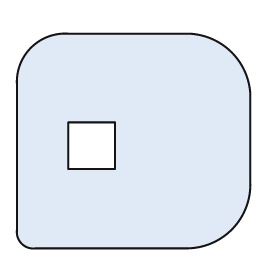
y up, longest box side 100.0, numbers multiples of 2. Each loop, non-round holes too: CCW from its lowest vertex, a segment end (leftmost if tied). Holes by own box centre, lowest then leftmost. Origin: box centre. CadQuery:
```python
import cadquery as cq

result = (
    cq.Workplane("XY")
    .moveTo(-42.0, -46.0)
    .lineTo(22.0, -46.0)
    .threePointArc((42.0, -38.0), (50.0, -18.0))
    .lineTo(50.0, 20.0)
    .threePointArc((42.0, 38.0), (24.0, 46.0))
    .lineTo(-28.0, 46.0)
    .threePointArc((-44.0, 40.0), (-50.0, 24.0))
    .lineTo(-50.0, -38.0)
    .threePointArc((-48.0, -44.0), (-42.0, -46.0))
    .close()
    .moveTo(-28.0, -12.0)
    .lineTo(-8.0, -12.0)
    .lineTo(-8.0, 8.0)
    .lineTo(-28.0, 8.0)
    .close()
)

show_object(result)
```